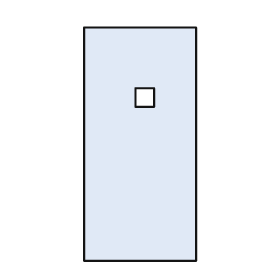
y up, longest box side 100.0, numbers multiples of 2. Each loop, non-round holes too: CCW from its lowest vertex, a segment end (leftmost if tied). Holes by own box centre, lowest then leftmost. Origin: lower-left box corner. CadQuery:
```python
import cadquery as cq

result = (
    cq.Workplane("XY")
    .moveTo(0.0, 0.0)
    .lineTo(48.0, 0.0)
    .lineTo(48.0, 100.0)
    .lineTo(0.0, 100.0)
    .close()
    .moveTo(22.0, 66.0)
    .lineTo(30.0, 66.0)
    .lineTo(30.0, 74.0)
    .lineTo(22.0, 74.0)
    .close()
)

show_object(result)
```